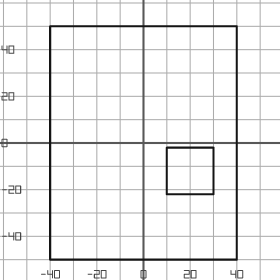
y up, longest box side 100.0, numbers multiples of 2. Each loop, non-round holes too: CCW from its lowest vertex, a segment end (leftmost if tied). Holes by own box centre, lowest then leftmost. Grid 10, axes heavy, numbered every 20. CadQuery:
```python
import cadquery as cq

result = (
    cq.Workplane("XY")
    .moveTo(-40.0, -50.0)
    .lineTo(40.0, -50.0)
    .lineTo(40.0, 50.0)
    .lineTo(-40.0, 50.0)
    .close()
    .moveTo(10.0, -22.0)
    .lineTo(30.0, -22.0)
    .lineTo(30.0, -2.0)
    .lineTo(10.0, -2.0)
    .close()
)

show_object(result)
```